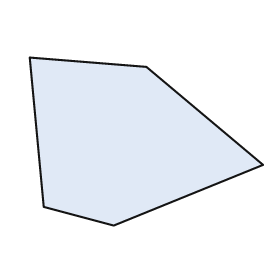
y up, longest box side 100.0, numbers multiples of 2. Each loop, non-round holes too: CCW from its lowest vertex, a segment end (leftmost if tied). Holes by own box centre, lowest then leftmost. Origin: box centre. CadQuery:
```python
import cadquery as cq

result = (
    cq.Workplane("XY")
    .moveTo(-14.0, -36.0)
    .lineTo(50.0, -10.0)
    .lineTo(0.0, 32.0)
    .lineTo(-50.0, 36.0)
    .lineTo(-44.0, -28.0)
    .close()
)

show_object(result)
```